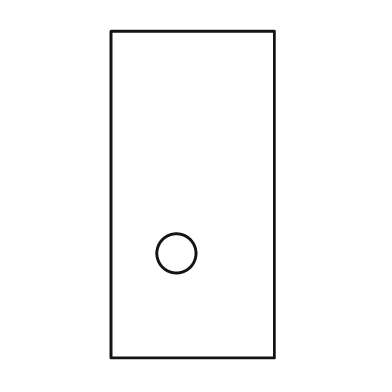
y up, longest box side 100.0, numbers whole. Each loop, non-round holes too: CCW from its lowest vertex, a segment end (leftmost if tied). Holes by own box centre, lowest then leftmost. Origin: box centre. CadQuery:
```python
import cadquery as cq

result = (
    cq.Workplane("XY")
    .moveTo(-25.0, -50.0)
    .lineTo(25.0, -50.0)
    .lineTo(25.0, 50.0)
    .lineTo(-25.0, 50.0)
    .close()
    .moveTo(-5.0, -18.0)
    .circle(6.0)
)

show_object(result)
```